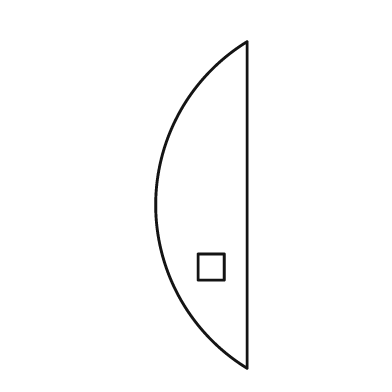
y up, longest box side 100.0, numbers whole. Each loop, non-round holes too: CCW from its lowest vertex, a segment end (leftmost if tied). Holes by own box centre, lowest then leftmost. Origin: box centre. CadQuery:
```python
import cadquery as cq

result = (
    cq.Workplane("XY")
    .moveTo(14.0, -50.0)
    .lineTo(14.0, 50.0)
    .threePointArc((-14.0, 0.0), (14.0, -50.0))
    .close()
    .moveTo(-1.0, -23.0)
    .lineTo(7.0, -23.0)
    .lineTo(7.0, -15.0)
    .lineTo(-1.0, -15.0)
    .close()
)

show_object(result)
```